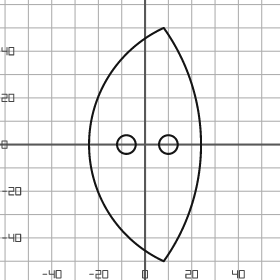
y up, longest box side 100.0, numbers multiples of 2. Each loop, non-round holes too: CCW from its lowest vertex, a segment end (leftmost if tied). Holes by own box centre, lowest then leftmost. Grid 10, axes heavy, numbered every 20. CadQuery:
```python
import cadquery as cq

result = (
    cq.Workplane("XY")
    .moveTo(8.0, -50.0)
    .threePointArc((24.0, 0.0), (8.0, 50.0))
    .threePointArc((-24.0, 0.0), (8.0, -50.0))
    .close()
    .moveTo(-8.0, 0.0)
    .circle(4.0)
    .moveTo(10.0, 0.0)
    .circle(4.0)
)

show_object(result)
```